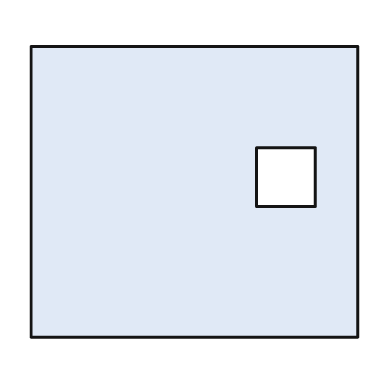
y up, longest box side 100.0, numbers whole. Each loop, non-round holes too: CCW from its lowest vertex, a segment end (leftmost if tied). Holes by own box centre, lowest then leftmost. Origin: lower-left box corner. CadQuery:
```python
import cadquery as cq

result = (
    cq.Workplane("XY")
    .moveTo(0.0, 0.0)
    .lineTo(100.0, 0.0)
    .lineTo(100.0, 89.0)
    .lineTo(0.0, 89.0)
    .close()
    .moveTo(69.0, 40.0)
    .lineTo(87.0, 40.0)
    .lineTo(87.0, 58.0)
    .lineTo(69.0, 58.0)
    .close()
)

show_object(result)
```